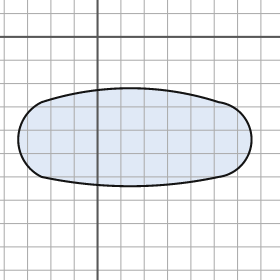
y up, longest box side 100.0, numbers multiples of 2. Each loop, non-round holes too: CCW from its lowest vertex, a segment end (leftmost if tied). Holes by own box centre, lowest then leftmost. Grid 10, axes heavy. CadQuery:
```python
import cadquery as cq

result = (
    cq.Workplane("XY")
    .moveTo(-24.0, -60.0)
    .threePointArc((14.0, -64.0), (52.0, -60.0))
    .threePointArc((66.0, -44.0), (52.0, -28.0))
    .threePointArc((14.0, -22.0), (-24.0, -28.0))
    .threePointArc((-34.0, -44.0), (-24.0, -60.0))
    .close()
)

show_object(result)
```